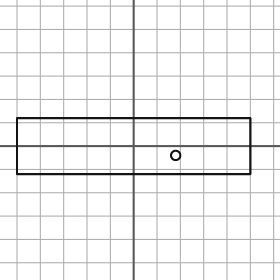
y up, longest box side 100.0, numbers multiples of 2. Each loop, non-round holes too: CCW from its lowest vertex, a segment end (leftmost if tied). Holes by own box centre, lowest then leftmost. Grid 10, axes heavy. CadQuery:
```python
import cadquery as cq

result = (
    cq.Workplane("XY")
    .moveTo(-50.0, -12.0)
    .lineTo(50.0, -12.0)
    .lineTo(50.0, 12.0)
    .lineTo(-50.0, 12.0)
    .close()
    .moveTo(18.0, -4.0)
    .circle(2.0)
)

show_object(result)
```